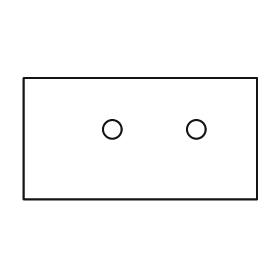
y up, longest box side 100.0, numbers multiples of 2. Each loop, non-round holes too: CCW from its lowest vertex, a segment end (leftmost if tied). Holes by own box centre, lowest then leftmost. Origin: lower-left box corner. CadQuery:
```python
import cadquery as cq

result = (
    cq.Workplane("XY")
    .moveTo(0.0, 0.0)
    .lineTo(100.0, 0.0)
    .lineTo(100.0, 52.0)
    .lineTo(0.0, 52.0)
    .close()
    .moveTo(38.0, 30.0)
    .circle(4.0)
    .moveTo(74.0, 30.0)
    .circle(4.0)
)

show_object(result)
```